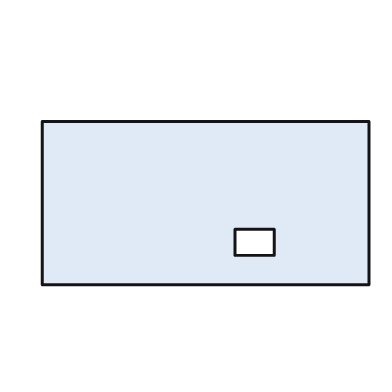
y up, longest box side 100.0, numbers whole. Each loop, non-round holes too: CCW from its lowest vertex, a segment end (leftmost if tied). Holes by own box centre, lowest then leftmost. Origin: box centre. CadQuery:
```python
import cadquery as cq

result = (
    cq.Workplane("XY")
    .moveTo(-50.0, -25.0)
    .lineTo(50.0, -25.0)
    .lineTo(50.0, 25.0)
    .lineTo(-50.0, 25.0)
    .close()
    .moveTo(9.0, -16.0)
    .lineTo(21.0, -16.0)
    .lineTo(21.0, -8.0)
    .lineTo(9.0, -8.0)
    .close()
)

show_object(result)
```